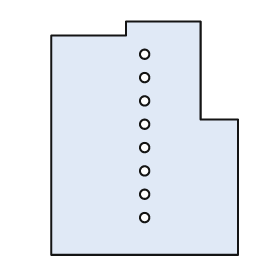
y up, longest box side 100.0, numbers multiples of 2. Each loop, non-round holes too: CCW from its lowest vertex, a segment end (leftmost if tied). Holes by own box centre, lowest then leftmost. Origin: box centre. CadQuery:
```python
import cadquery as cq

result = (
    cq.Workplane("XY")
    .moveTo(-40.0, -50.0)
    .lineTo(40.0, -50.0)
    .lineTo(40.0, 8.0)
    .lineTo(24.0, 8.0)
    .lineTo(24.0, 50.0)
    .lineTo(-8.0, 50.0)
    .lineTo(-8.0, 44.0)
    .lineTo(-40.0, 44.0)
    .close()
    .moveTo(0.0, -34.0)
    .circle(2.0)
    .moveTo(0.0, -24.0)
    .circle(2.0)
    .moveTo(0.0, -14.0)
    .circle(2.0)
    .moveTo(0.0, -4.0)
    .circle(2.0)
    .moveTo(0.0, 6.0)
    .circle(2.0)
    .moveTo(0.0, 16.0)
    .circle(2.0)
    .moveTo(0.0, 26.0)
    .circle(2.0)
    .moveTo(0.0, 36.0)
    .circle(2.0)
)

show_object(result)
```